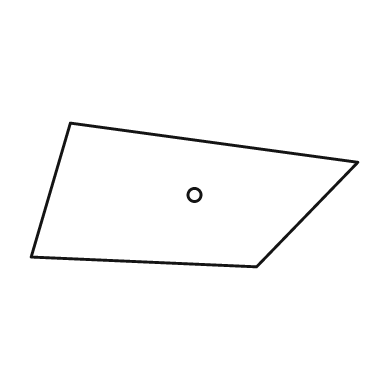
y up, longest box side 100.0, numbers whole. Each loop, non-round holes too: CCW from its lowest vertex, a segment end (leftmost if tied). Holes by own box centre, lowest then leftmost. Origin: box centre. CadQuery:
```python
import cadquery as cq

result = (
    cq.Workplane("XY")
    .moveTo(19.0, -22.0)
    .lineTo(50.0, 10.0)
    .lineTo(-38.0, 22.0)
    .lineTo(-50.0, -19.0)
    .close()
    .moveTo(0.0, 0.0)
    .circle(2.0)
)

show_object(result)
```